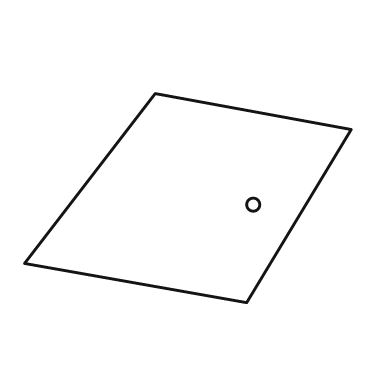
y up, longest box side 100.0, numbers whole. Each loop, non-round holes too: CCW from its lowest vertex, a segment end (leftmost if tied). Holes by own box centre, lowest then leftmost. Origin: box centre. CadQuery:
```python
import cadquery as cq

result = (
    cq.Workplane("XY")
    .moveTo(18.0, -32.0)
    .lineTo(50.0, 21.0)
    .lineTo(-10.0, 32.0)
    .lineTo(-50.0, -20.0)
    .close()
    .moveTo(20.0, -2.0)
    .circle(2.0)
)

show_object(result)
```